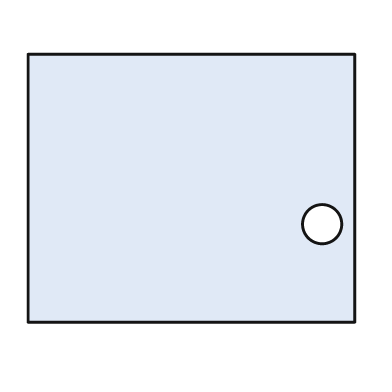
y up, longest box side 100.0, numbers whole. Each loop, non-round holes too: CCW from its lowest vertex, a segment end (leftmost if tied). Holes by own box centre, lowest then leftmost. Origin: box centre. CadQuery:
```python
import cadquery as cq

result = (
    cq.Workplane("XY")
    .moveTo(-50.0, -41.0)
    .lineTo(50.0, -41.0)
    .lineTo(50.0, 41.0)
    .lineTo(-50.0, 41.0)
    .close()
    .moveTo(40.0, -11.0)
    .circle(6.0)
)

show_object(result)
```